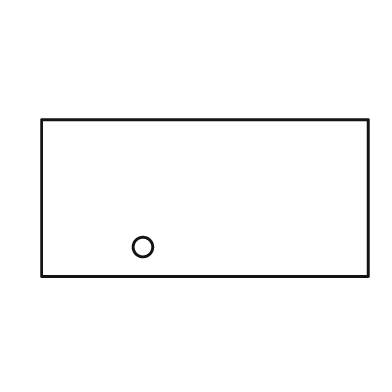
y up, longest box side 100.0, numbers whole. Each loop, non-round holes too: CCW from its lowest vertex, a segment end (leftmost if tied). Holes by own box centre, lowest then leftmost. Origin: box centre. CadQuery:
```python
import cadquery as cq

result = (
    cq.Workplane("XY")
    .moveTo(-50.0, -24.0)
    .lineTo(50.0, -24.0)
    .lineTo(50.0, 24.0)
    .lineTo(-50.0, 24.0)
    .close()
    .moveTo(-19.0, -15.0)
    .circle(3.0)
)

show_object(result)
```